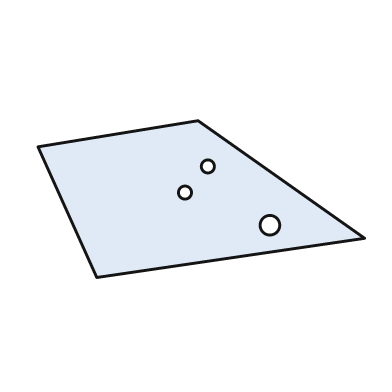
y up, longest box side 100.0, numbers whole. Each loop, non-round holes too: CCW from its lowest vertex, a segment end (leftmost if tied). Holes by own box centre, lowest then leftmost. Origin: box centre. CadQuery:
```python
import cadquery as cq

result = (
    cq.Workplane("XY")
    .moveTo(-32.0, -24.0)
    .lineTo(50.0, -12.0)
    .lineTo(-1.0, 24.0)
    .lineTo(-50.0, 16.0)
    .close()
    .moveTo(21.0, -8.0)
    .circle(3.0)
    .moveTo(-5.0, 2.0)
    .circle(2.0)
    .moveTo(2.0, 10.0)
    .circle(2.0)
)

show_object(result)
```